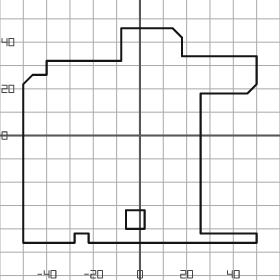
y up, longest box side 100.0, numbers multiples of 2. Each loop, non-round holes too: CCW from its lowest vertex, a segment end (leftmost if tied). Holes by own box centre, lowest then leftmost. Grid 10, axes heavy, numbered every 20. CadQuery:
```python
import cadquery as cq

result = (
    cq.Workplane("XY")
    .moveTo(-50.0, -46.0)
    .lineTo(-28.0, -46.0)
    .lineTo(-28.0, -42.0)
    .lineTo(-22.0, -42.0)
    .lineTo(-22.0, -46.0)
    .lineTo(50.0, -46.0)
    .lineTo(50.0, -42.0)
    .lineTo(26.0, -42.0)
    .lineTo(26.0, 18.0)
    .lineTo(46.0, 18.0)
    .lineTo(50.0, 22.0)
    .lineTo(50.0, 34.0)
    .lineTo(18.0, 34.0)
    .lineTo(18.0, 42.0)
    .lineTo(14.0, 46.0)
    .lineTo(-8.0, 46.0)
    .lineTo(-8.0, 32.0)
    .lineTo(-40.0, 32.0)
    .lineTo(-40.0, 26.0)
    .lineTo(-46.0, 26.0)
    .lineTo(-50.0, 22.0)
    .close()
    .moveTo(-6.0, -40.0)
    .lineTo(2.0, -40.0)
    .lineTo(2.0, -32.0)
    .lineTo(-6.0, -32.0)
    .close()
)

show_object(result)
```